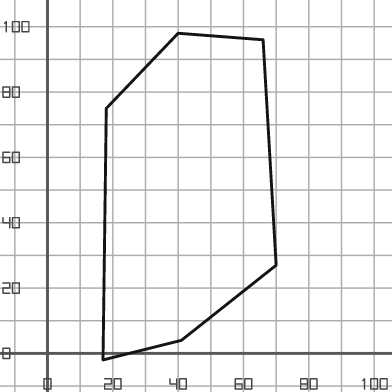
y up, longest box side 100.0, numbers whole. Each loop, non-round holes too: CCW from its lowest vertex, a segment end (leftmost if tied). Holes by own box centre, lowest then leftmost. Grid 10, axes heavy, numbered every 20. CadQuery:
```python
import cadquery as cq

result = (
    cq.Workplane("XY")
    .moveTo(17.0, -2.0)
    .lineTo(41.0, 4.0)
    .lineTo(70.0, 27.0)
    .lineTo(66.0, 96.0)
    .lineTo(40.0, 98.0)
    .lineTo(18.0, 75.0)
    .close()
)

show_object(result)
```